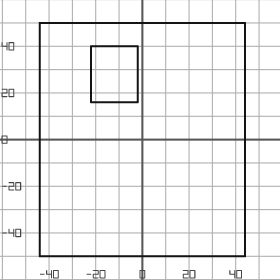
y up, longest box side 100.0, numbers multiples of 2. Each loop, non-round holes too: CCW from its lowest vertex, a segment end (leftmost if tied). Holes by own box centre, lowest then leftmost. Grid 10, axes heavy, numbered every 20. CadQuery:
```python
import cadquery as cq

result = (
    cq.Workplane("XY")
    .moveTo(-44.0, -50.0)
    .lineTo(44.0, -50.0)
    .lineTo(44.0, 50.0)
    .lineTo(-44.0, 50.0)
    .close()
    .moveTo(-22.0, 16.0)
    .lineTo(-2.0, 16.0)
    .lineTo(-2.0, 40.0)
    .lineTo(-22.0, 40.0)
    .close()
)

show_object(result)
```